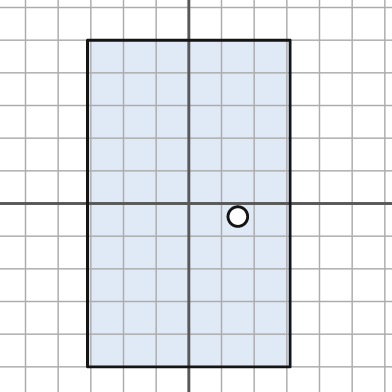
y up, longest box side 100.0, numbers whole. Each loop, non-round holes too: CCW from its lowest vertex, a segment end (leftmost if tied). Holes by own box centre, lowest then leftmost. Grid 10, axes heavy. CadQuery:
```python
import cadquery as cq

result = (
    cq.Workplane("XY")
    .moveTo(-31.0, -50.0)
    .lineTo(31.0, -50.0)
    .lineTo(31.0, 50.0)
    .lineTo(-31.0, 50.0)
    .close()
    .moveTo(15.0, -4.0)
    .circle(3.0)
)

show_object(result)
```